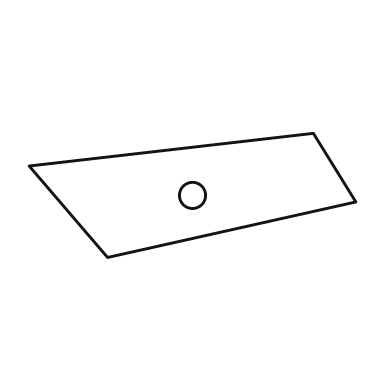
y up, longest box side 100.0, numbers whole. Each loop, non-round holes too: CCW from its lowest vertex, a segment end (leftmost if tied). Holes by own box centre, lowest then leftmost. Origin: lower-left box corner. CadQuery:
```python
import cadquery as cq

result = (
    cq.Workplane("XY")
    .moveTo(24.0, 0.0)
    .lineTo(100.0, 17.0)
    .lineTo(87.0, 38.0)
    .lineTo(0.0, 28.0)
    .close()
    .moveTo(50.0, 19.0)
    .circle(4.0)
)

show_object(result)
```